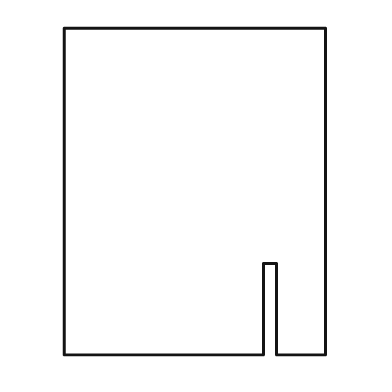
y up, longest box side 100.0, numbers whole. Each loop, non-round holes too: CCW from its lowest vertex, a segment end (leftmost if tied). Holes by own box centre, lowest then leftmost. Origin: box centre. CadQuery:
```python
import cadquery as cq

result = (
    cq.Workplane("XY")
    .moveTo(-40.0, -50.0)
    .lineTo(21.0, -50.0)
    .lineTo(21.0, -22.0)
    .lineTo(25.0, -22.0)
    .lineTo(25.0, -50.0)
    .lineTo(40.0, -50.0)
    .lineTo(40.0, 50.0)
    .lineTo(-40.0, 50.0)
    .close()
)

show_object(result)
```